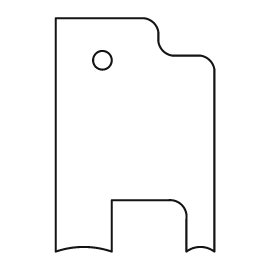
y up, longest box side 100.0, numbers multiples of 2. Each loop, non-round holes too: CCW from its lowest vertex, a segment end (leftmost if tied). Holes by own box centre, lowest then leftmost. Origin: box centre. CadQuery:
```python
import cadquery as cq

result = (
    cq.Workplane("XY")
    .moveTo(-34.0, -50.0)
    .threePointArc((-22.0, -48.0), (-10.0, -50.0))
    .lineTo(-10.0, -28.0)
    .lineTo(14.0, -28.0)
    .threePointArc((20.0, -30.0), (22.0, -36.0))
    .lineTo(22.0, -50.0)
    .threePointArc((28.0, -48.0), (34.0, -50.0))
    .lineTo(34.0, 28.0)
    .threePointArc((32.0, 32.0), (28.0, 34.0))
    .lineTo(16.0, 34.0)
    .threePointArc((12.0, 36.0), (10.0, 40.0))
    .lineTo(10.0, 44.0)
    .threePointArc((8.0, 48.0), (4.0, 50.0))
    .lineTo(-34.0, 50.0)
    .close()
    .moveTo(-14.0, 32.0)
    .circle(4.0)
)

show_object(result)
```